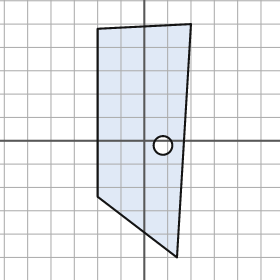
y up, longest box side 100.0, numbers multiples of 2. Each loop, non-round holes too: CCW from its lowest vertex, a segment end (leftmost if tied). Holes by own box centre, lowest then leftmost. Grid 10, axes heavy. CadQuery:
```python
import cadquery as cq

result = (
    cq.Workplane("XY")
    .moveTo(14.0, -50.0)
    .lineTo(20.0, 50.0)
    .lineTo(-20.0, 48.0)
    .lineTo(-20.0, -24.0)
    .close()
    .moveTo(8.0, -2.0)
    .circle(4.0)
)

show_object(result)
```